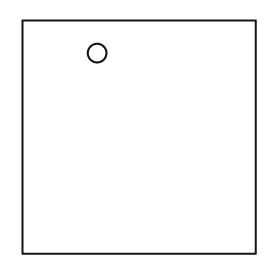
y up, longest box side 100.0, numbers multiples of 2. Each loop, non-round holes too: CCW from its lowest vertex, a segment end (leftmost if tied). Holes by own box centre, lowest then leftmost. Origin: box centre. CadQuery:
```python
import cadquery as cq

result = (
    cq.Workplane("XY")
    .moveTo(-50.0, -50.0)
    .lineTo(50.0, -50.0)
    .lineTo(50.0, 50.0)
    .lineTo(-50.0, 50.0)
    .close()
    .moveTo(-18.0, 36.0)
    .circle(4.0)
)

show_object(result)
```